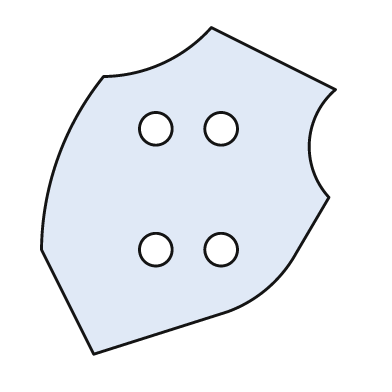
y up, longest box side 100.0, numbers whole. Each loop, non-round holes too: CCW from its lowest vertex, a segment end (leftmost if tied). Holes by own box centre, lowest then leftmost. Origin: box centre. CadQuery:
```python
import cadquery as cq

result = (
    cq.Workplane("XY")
    .moveTo(-29.0, -50.0)
    .lineTo(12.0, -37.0)
    .threePointArc((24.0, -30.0), (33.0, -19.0))
    .lineTo(43.0, -2.0)
    .threePointArc((37.0, 15.0), (45.0, 31.0))
    .lineTo(7.0, 50.0)
    .threePointArc((-8.0, 39.0), (-26.0, 35.0))
    .threePointArc((-40.0, 10.0), (-45.0, -18.0))
    .close()
    .moveTo(-10.0, -18.0)
    .circle(5.0)
    .moveTo(10.0, -18.0)
    .circle(5.0)
    .moveTo(-10.0, 19.0)
    .circle(5.0)
    .moveTo(10.0, 19.0)
    .circle(5.0)
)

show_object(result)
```